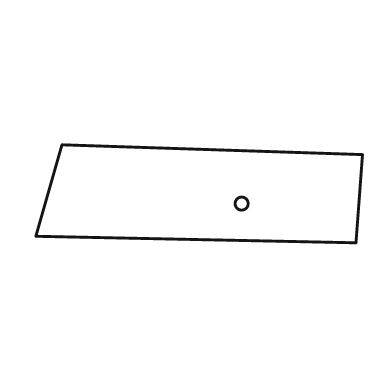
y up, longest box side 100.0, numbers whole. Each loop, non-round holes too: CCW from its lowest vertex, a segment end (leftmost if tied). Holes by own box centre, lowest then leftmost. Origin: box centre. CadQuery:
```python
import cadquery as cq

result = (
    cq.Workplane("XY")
    .moveTo(48.0, -15.0)
    .lineTo(50.0, 12.0)
    .lineTo(-42.0, 15.0)
    .lineTo(-50.0, -13.0)
    .close()
    .moveTo(13.0, -3.0)
    .circle(2.0)
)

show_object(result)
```